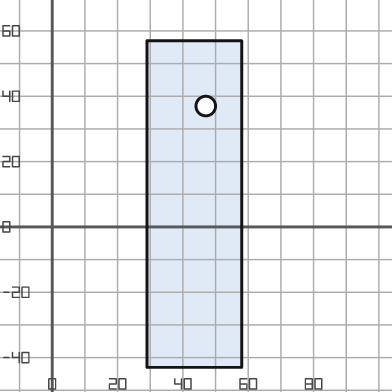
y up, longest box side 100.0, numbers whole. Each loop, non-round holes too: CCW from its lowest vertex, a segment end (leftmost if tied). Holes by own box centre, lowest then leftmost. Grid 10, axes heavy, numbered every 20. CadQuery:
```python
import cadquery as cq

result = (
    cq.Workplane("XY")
    .moveTo(29.0, -43.0)
    .lineTo(58.0, -43.0)
    .lineTo(58.0, 57.0)
    .lineTo(29.0, 57.0)
    .close()
    .moveTo(47.0, 37.0)
    .circle(3.0)
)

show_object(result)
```